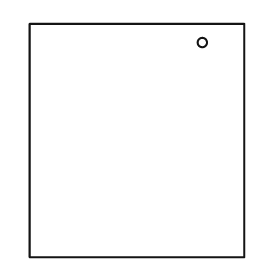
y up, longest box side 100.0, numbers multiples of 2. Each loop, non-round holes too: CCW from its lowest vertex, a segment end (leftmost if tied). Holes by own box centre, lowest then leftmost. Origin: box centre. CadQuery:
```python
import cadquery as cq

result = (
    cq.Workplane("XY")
    .moveTo(-46.0, -50.0)
    .lineTo(46.0, -50.0)
    .lineTo(46.0, 50.0)
    .lineTo(-46.0, 50.0)
    .close()
    .moveTo(28.0, 42.0)
    .circle(2.0)
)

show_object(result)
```